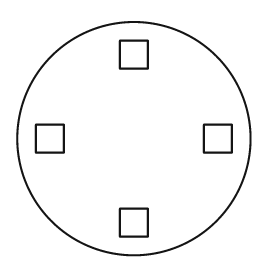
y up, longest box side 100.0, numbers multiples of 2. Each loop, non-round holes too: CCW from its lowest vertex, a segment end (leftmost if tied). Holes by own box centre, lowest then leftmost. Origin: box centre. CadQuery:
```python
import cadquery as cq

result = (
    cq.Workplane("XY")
    .moveTo(0.0, 0.0)
    .circle(50.0)
    .moveTo(-6.0, -42.0)
    .lineTo(6.0, -42.0)
    .lineTo(6.0, -30.0)
    .lineTo(-6.0, -30.0)
    .close()
    .moveTo(-42.0, -6.0)
    .lineTo(-30.0, -6.0)
    .lineTo(-30.0, 6.0)
    .lineTo(-42.0, 6.0)
    .close()
    .moveTo(30.0, -6.0)
    .lineTo(42.0, -6.0)
    .lineTo(42.0, 6.0)
    .lineTo(30.0, 6.0)
    .close()
    .moveTo(-6.0, 30.0)
    .lineTo(6.0, 30.0)
    .lineTo(6.0, 42.0)
    .lineTo(-6.0, 42.0)
    .close()
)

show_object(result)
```